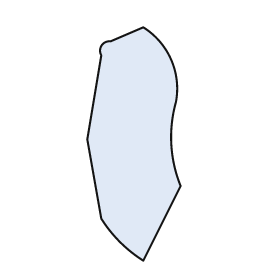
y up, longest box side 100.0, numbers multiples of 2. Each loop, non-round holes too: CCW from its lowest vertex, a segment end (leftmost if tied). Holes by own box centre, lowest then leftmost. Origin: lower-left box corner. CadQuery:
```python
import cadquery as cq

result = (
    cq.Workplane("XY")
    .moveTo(24.0, 0.0)
    .lineTo(40.0, 32.0)
    .threePointArc((36.0, 50.0), (38.0, 68.0))
    .threePointArc((36.0, 86.0), (24.0, 100.0))
    .lineTo(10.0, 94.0)
    .threePointArc((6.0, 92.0), (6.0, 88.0))
    .lineTo(0.0, 52.0)
    .lineTo(6.0, 18.0)
    .threePointArc((14.0, 8.0), (24.0, 0.0))
    .close()
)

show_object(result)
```